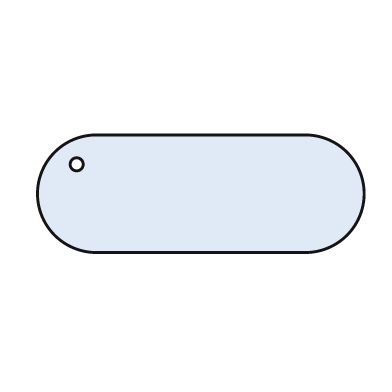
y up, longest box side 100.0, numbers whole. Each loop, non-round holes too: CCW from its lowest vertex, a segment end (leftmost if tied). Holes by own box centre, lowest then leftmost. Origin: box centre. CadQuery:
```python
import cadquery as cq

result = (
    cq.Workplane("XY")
    .moveTo(-32.0, -18.0)
    .lineTo(32.0, -18.0)
    .threePointArc((50.0, 0.0), (32.0, 18.0))
    .lineTo(-32.0, 18.0)
    .threePointArc((-50.0, 0.0), (-32.0, -18.0))
    .close()
    .moveTo(-38.0, 9.0)
    .circle(2.0)
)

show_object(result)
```